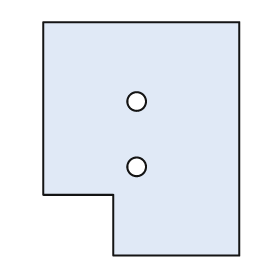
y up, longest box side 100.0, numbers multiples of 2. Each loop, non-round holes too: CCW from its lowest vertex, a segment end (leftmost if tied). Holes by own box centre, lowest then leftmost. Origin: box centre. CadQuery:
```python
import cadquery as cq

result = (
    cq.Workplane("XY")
    .moveTo(-12.0, -50.0)
    .lineTo(42.0, -50.0)
    .lineTo(42.0, 50.0)
    .lineTo(-42.0, 50.0)
    .lineTo(-42.0, -24.0)
    .lineTo(-12.0, -24.0)
    .close()
    .moveTo(-2.0, -12.0)
    .circle(4.0)
    .moveTo(-2.0, 16.0)
    .circle(4.0)
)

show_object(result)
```